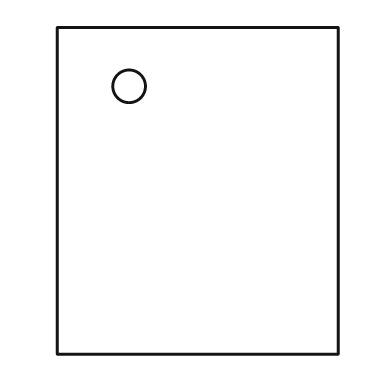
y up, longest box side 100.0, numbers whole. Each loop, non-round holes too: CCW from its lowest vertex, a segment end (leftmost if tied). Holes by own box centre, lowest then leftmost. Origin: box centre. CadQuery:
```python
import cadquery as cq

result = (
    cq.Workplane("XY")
    .moveTo(-43.0, -50.0)
    .lineTo(43.0, -50.0)
    .lineTo(43.0, 50.0)
    .lineTo(-43.0, 50.0)
    .close()
    .moveTo(-21.0, 32.0)
    .circle(5.0)
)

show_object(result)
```